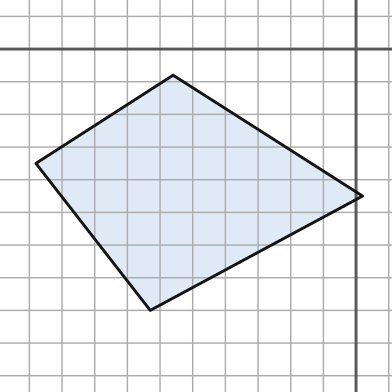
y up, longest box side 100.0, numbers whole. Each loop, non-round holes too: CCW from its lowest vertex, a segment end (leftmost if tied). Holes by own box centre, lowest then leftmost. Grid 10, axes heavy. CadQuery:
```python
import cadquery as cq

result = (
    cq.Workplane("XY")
    .moveTo(-63.0, -80.0)
    .lineTo(2.0, -45.0)
    .lineTo(-56.0, -8.0)
    .lineTo(-98.0, -35.0)
    .close()
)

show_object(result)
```